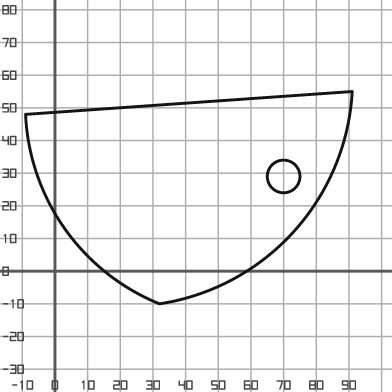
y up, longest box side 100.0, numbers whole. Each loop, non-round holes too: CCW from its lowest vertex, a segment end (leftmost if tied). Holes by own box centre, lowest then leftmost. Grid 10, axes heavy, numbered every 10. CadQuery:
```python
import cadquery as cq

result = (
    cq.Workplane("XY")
    .moveTo(32.0, -10.0)
    .threePointArc((73.0, 12.0), (91.0, 55.0))
    .lineTo(-9.0, 48.0)
    .threePointArc((3.0, 13.0), (32.0, -10.0))
    .close()
    .moveTo(70.0, 29.0)
    .circle(5.0)
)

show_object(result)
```